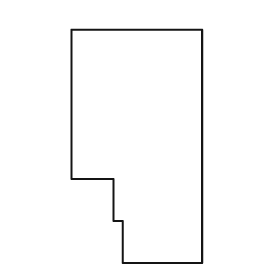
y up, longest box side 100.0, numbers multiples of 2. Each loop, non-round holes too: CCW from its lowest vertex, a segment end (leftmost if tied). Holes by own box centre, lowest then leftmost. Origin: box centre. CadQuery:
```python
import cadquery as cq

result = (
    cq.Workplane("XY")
    .moveTo(-6.0, -50.0)
    .lineTo(28.0, -50.0)
    .lineTo(28.0, 50.0)
    .lineTo(-28.0, 50.0)
    .lineTo(-28.0, -14.0)
    .lineTo(-10.0, -14.0)
    .lineTo(-10.0, -32.0)
    .lineTo(-6.0, -32.0)
    .close()
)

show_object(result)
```